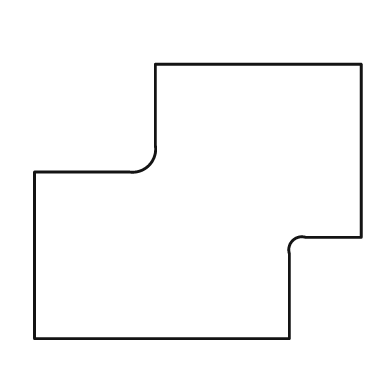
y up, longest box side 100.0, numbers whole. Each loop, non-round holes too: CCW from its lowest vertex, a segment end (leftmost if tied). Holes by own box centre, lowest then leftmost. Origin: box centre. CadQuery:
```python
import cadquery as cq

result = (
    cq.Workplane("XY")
    .moveTo(-50.0, -42.0)
    .lineTo(28.0, -42.0)
    .lineTo(28.0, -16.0)
    .threePointArc((29.0, -12.0), (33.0, -11.0))
    .lineTo(50.0, -11.0)
    .lineTo(50.0, 42.0)
    .lineTo(-13.0, 42.0)
    .lineTo(-13.0, 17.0)
    .threePointArc((-15.0, 11.0), (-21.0, 9.0))
    .lineTo(-50.0, 9.0)
    .close()
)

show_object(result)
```